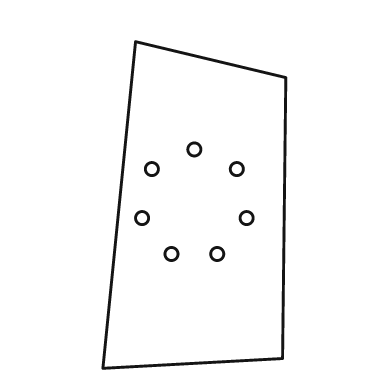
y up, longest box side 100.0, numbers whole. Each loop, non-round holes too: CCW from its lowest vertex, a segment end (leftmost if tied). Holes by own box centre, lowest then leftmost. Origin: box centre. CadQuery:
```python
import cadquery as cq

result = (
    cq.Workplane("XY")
    .moveTo(-28.0, -50.0)
    .lineTo(27.0, -47.0)
    .lineTo(28.0, 39.0)
    .lineTo(-18.0, 50.0)
    .close()
    .moveTo(-7.0, -15.0)
    .circle(2.0)
    .moveTo(7.0, -15.0)
    .circle(2.0)
    .moveTo(-16.0, -4.0)
    .circle(2.0)
    .moveTo(16.0, -4.0)
    .circle(2.0)
    .moveTo(-13.0, 11.0)
    .circle(2.0)
    .moveTo(13.0, 11.0)
    .circle(2.0)
    .moveTo(0.0, 17.0)
    .circle(2.0)
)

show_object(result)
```